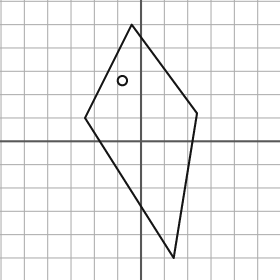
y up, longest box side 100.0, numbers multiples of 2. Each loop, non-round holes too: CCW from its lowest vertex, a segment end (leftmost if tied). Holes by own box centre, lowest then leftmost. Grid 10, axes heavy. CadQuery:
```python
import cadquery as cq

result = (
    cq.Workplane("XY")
    .moveTo(14.0, -50.0)
    .lineTo(24.0, 12.0)
    .lineTo(-4.0, 50.0)
    .lineTo(-24.0, 10.0)
    .close()
    .moveTo(-8.0, 26.0)
    .circle(2.0)
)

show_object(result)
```